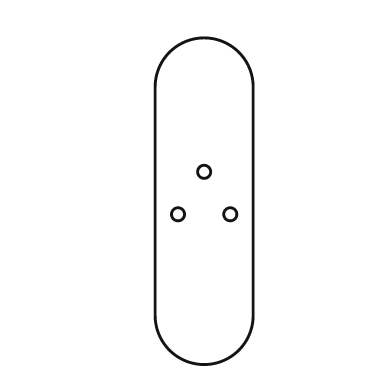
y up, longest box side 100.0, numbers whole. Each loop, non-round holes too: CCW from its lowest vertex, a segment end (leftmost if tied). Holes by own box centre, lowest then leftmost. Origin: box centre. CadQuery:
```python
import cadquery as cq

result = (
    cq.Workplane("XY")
    .moveTo(-15.0, -35.0)
    .threePointArc((0.0, -50.0), (15.0, -35.0))
    .lineTo(15.0, 35.0)
    .threePointArc((0.0, 50.0), (-15.0, 35.0))
    .close()
    .moveTo(-8.0, -4.0)
    .circle(2.0)
    .moveTo(8.0, -4.0)
    .circle(2.0)
    .moveTo(0.0, 9.0)
    .circle(2.0)
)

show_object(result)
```